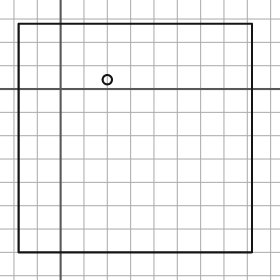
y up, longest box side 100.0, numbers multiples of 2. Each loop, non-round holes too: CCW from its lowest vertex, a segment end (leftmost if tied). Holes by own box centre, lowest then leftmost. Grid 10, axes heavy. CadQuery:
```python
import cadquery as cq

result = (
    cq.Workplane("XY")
    .moveTo(-18.0, -70.0)
    .lineTo(82.0, -70.0)
    .lineTo(82.0, 28.0)
    .lineTo(-18.0, 28.0)
    .close()
    .moveTo(20.0, 4.0)
    .circle(2.0)
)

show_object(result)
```